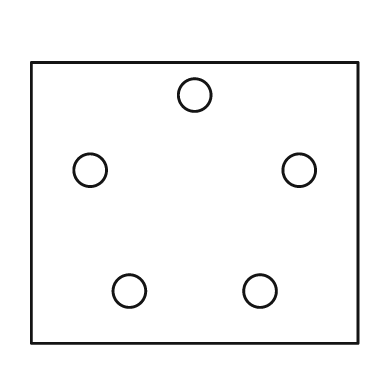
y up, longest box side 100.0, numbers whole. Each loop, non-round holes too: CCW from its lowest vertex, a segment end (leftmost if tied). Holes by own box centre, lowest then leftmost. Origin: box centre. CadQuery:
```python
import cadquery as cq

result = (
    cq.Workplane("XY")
    .moveTo(-50.0, -43.0)
    .lineTo(50.0, -43.0)
    .lineTo(50.0, 43.0)
    .lineTo(-50.0, 43.0)
    .close()
    .moveTo(-20.0, -27.0)
    .circle(5.0)
    .moveTo(20.0, -27.0)
    .circle(5.0)
    .moveTo(-32.0, 10.0)
    .circle(5.0)
    .moveTo(32.0, 10.0)
    .circle(5.0)
    .moveTo(0.0, 33.0)
    .circle(5.0)
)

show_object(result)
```